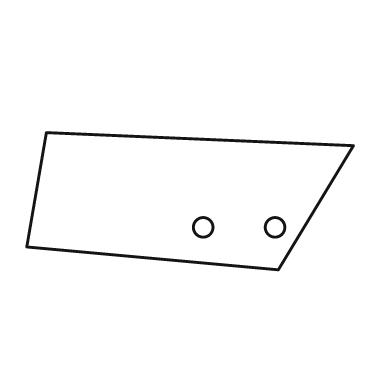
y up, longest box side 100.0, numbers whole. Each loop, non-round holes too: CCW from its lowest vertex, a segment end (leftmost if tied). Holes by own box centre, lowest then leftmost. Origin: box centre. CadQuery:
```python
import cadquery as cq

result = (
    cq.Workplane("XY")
    .moveTo(27.0, -21.0)
    .lineTo(50.0, 17.0)
    .lineTo(-44.0, 21.0)
    .lineTo(-50.0, -14.0)
    .close()
    .moveTo(4.0, -8.0)
    .circle(3.0)
    .moveTo(26.0, -8.0)
    .circle(3.0)
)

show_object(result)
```